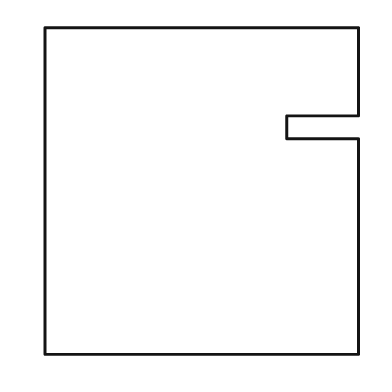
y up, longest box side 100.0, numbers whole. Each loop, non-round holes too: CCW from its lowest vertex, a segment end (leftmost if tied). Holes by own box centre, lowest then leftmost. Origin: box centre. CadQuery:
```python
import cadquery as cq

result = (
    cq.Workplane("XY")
    .moveTo(-48.0, -50.0)
    .lineTo(48.0, -50.0)
    .lineTo(48.0, 16.0)
    .lineTo(26.0, 16.0)
    .lineTo(26.0, 23.0)
    .lineTo(48.0, 23.0)
    .lineTo(48.0, 50.0)
    .lineTo(-48.0, 50.0)
    .close()
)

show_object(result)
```